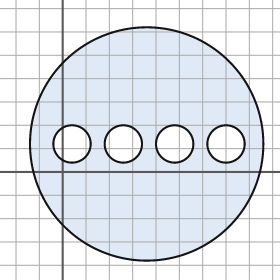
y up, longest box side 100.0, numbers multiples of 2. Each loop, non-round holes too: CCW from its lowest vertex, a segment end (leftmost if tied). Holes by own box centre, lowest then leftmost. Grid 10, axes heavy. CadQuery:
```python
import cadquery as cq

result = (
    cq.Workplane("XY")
    .moveTo(36.0, 12.0)
    .circle(50.0)
    .moveTo(4.0, 12.0)
    .circle(8.0)
    .moveTo(26.0, 12.0)
    .circle(8.0)
    .moveTo(48.0, 12.0)
    .circle(8.0)
    .moveTo(70.0, 12.0)
    .circle(8.0)
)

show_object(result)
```